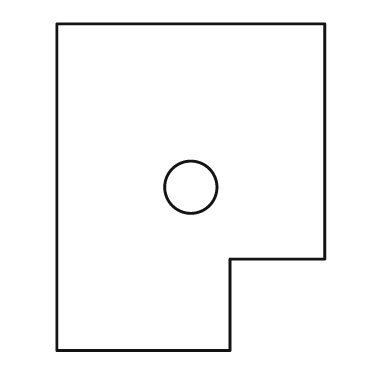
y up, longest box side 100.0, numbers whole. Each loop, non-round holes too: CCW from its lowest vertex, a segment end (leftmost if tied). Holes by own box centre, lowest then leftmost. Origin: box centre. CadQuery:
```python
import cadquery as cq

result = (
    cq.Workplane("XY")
    .moveTo(-41.0, -50.0)
    .lineTo(12.0, -50.0)
    .lineTo(12.0, -22.0)
    .lineTo(41.0, -22.0)
    .lineTo(41.0, 50.0)
    .lineTo(-41.0, 50.0)
    .close()
    .moveTo(0.0, 0.0)
    .circle(8.0)
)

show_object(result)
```